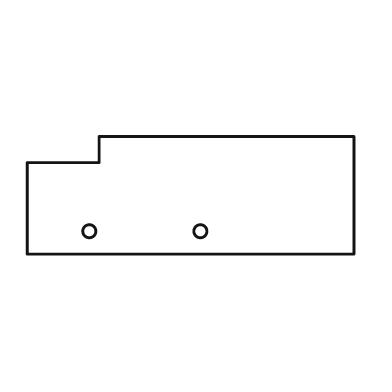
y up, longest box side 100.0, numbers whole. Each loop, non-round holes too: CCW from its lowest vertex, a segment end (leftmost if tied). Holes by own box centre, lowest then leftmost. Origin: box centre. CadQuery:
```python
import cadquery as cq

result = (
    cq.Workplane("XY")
    .moveTo(-50.0, -18.0)
    .lineTo(50.0, -18.0)
    .lineTo(50.0, 18.0)
    .lineTo(-28.0, 18.0)
    .lineTo(-28.0, 10.0)
    .lineTo(-50.0, 10.0)
    .close()
    .moveTo(-31.0, -11.0)
    .circle(2.0)
    .moveTo(3.0, -11.0)
    .circle(2.0)
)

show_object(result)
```